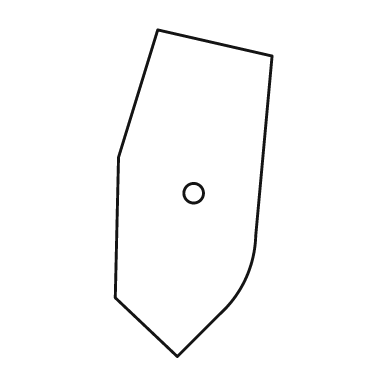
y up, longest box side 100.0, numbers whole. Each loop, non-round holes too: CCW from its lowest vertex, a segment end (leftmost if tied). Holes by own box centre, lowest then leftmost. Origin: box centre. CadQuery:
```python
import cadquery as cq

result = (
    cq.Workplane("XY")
    .moveTo(-5.0, -50.0)
    .lineTo(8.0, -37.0)
    .threePointArc((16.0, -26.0), (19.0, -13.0))
    .lineTo(24.0, 42.0)
    .lineTo(-11.0, 50.0)
    .lineTo(-23.0, 11.0)
    .lineTo(-24.0, -32.0)
    .close()
    .moveTo(0.0, 0.0)
    .circle(3.0)
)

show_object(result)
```